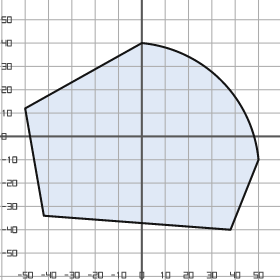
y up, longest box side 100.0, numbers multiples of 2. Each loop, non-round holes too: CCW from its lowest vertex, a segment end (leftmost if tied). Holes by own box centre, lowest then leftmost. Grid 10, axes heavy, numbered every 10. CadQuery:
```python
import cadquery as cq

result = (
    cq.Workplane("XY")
    .moveTo(38.0, -40.0)
    .lineTo(50.0, -10.0)
    .threePointArc((34.0, 24.0), (0.0, 40.0))
    .lineTo(-50.0, 12.0)
    .lineTo(-42.0, -34.0)
    .close()
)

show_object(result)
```